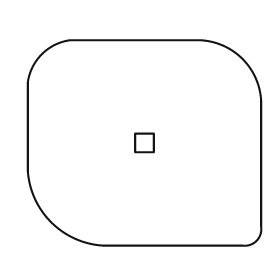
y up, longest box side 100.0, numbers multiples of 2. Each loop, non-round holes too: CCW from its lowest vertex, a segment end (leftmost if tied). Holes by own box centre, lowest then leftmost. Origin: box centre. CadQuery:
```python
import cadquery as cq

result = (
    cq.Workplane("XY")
    .moveTo(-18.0, -44.0)
    .lineTo(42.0, -44.0)
    .threePointArc((48.0, -42.0), (50.0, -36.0))
    .lineTo(50.0, 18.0)
    .threePointArc((42.0, 36.0), (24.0, 44.0))
    .lineTo(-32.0, 44.0)
    .threePointArc((-44.0, 38.0), (-50.0, 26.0))
    .lineTo(-50.0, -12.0)
    .threePointArc((-40.0, -34.0), (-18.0, -44.0))
    .close()
    .moveTo(-4.0, -4.0)
    .lineTo(4.0, -4.0)
    .lineTo(4.0, 4.0)
    .lineTo(-4.0, 4.0)
    .close()
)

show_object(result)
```